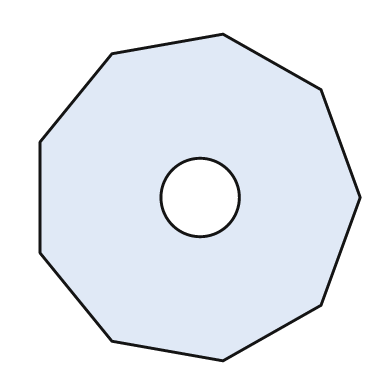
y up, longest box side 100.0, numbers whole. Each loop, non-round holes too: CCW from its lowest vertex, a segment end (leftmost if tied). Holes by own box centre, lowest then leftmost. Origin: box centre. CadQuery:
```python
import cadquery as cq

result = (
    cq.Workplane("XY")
    .moveTo(7.0, -50.0)
    .lineTo(37.0, -33.0)
    .lineTo(49.0, 0.0)
    .lineTo(37.0, 33.0)
    .lineTo(7.0, 50.0)
    .lineTo(-27.0, 44.0)
    .lineTo(-49.0, 17.0)
    .lineTo(-49.0, -17.0)
    .lineTo(-27.0, -44.0)
    .close()
    .moveTo(0.0, 0.0)
    .circle(12.0)
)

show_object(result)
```